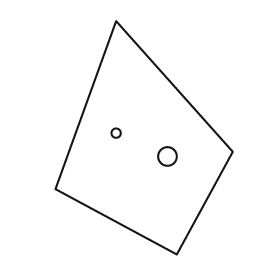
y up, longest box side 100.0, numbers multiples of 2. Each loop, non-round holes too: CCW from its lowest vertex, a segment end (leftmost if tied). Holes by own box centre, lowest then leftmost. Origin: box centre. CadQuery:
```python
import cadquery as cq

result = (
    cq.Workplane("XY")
    .moveTo(14.0, -50.0)
    .lineTo(38.0, -6.0)
    .lineTo(-12.0, 50.0)
    .lineTo(-38.0, -22.0)
    .close()
    .moveTo(10.0, -8.0)
    .circle(4.0)
    .moveTo(-12.0, 2.0)
    .circle(2.0)
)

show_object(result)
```